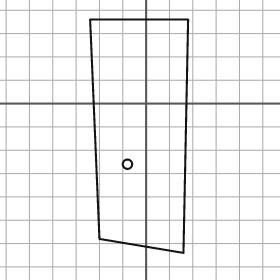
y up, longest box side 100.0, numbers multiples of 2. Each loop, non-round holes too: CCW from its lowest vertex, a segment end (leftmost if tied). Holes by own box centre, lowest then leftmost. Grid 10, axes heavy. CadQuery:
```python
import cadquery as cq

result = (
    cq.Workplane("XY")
    .moveTo(16.0, -64.0)
    .lineTo(18.0, 36.0)
    .lineTo(-24.0, 36.0)
    .lineTo(-20.0, -58.0)
    .close()
    .moveTo(-8.0, -26.0)
    .circle(2.0)
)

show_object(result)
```